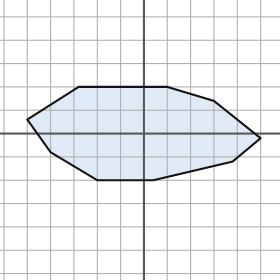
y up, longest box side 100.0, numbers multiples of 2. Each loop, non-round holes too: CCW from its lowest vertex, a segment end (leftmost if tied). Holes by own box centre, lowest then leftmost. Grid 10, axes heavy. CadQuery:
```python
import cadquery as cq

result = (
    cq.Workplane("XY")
    .moveTo(-20.0, -20.0)
    .lineTo(4.0, -20.0)
    .lineTo(38.0, -12.0)
    .lineTo(50.0, -2.0)
    .lineTo(30.0, 14.0)
    .lineTo(10.0, 20.0)
    .lineTo(-28.0, 20.0)
    .lineTo(-50.0, 6.0)
    .lineTo(-40.0, -8.0)
    .close()
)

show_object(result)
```